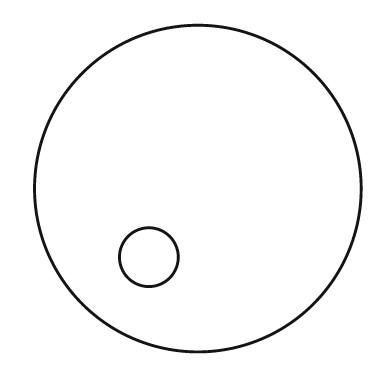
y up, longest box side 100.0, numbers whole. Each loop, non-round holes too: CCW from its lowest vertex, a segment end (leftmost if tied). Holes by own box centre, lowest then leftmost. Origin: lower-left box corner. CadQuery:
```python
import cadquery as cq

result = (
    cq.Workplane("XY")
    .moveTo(50.0, 50.0)
    .circle(50.0)
    .moveTo(35.0, 29.0)
    .circle(9.0)
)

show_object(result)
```